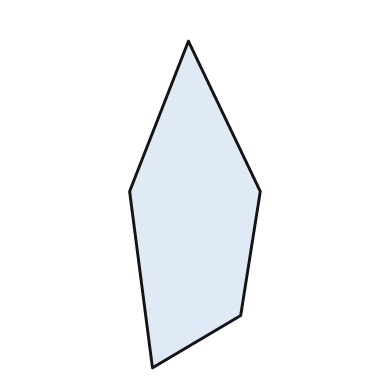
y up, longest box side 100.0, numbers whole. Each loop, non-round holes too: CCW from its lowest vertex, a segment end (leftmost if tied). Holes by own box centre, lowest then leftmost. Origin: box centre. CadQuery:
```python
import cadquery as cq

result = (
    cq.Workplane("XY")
    .moveTo(-13.0, -50.0)
    .lineTo(14.0, -34.0)
    .lineTo(20.0, 4.0)
    .lineTo(-2.0, 50.0)
    .lineTo(-20.0, 4.0)
    .close()
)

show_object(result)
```